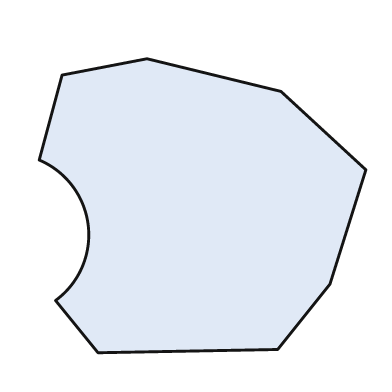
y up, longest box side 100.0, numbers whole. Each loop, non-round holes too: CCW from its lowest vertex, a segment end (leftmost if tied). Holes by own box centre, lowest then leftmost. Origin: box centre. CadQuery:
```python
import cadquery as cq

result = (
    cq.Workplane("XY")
    .moveTo(-32.0, -45.0)
    .lineTo(23.0, -44.0)
    .lineTo(39.0, -24.0)
    .lineTo(50.0, 11.0)
    .lineTo(24.0, 35.0)
    .lineTo(-17.0, 45.0)
    .lineTo(-43.0, 40.0)
    .lineTo(-50.0, 14.0)
    .threePointArc((-35.0, -6.0), (-45.0, -29.0))
    .close()
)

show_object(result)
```